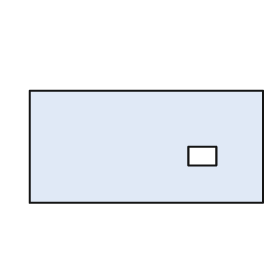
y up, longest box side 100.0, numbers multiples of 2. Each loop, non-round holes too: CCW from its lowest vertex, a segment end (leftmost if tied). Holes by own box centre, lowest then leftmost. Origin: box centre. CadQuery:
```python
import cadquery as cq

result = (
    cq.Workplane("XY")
    .moveTo(-50.0, -24.0)
    .lineTo(50.0, -24.0)
    .lineTo(50.0, 24.0)
    .lineTo(-50.0, 24.0)
    .close()
    .moveTo(18.0, -8.0)
    .lineTo(30.0, -8.0)
    .lineTo(30.0, 0.0)
    .lineTo(18.0, 0.0)
    .close()
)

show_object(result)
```